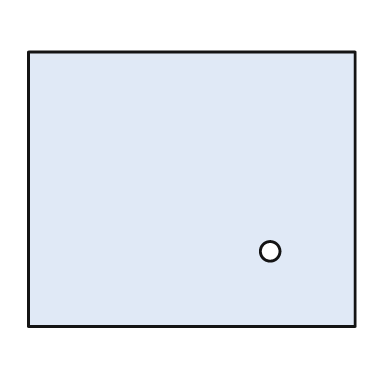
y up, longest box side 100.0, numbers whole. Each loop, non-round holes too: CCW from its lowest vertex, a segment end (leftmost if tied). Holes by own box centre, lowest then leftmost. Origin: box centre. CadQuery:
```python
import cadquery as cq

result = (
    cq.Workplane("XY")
    .moveTo(-50.0, -42.0)
    .lineTo(50.0, -42.0)
    .lineTo(50.0, 42.0)
    .lineTo(-50.0, 42.0)
    .close()
    .moveTo(24.0, -19.0)
    .circle(3.0)
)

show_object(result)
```